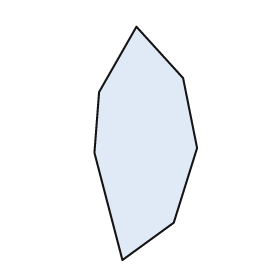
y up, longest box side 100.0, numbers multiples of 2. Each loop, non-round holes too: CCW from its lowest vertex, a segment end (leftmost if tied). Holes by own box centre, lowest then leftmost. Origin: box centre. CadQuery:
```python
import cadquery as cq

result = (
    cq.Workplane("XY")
    .moveTo(-10.0, -50.0)
    .lineTo(12.0, -34.0)
    .lineTo(22.0, -2.0)
    .lineTo(16.0, 28.0)
    .lineTo(-4.0, 50.0)
    .lineTo(-20.0, 22.0)
    .lineTo(-22.0, -4.0)
    .close()
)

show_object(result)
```